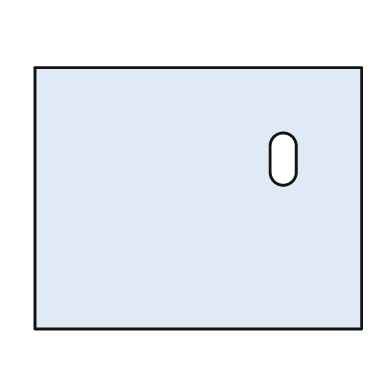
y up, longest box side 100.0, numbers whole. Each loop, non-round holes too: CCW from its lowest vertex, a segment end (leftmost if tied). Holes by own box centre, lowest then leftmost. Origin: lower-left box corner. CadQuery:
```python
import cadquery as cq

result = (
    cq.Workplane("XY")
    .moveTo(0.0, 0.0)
    .lineTo(100.0, 0.0)
    .lineTo(100.0, 80.0)
    .lineTo(0.0, 80.0)
    .close()
    .moveTo(72.0, 48.0)
    .threePointArc((76.0, 44.0), (80.0, 48.0))
    .lineTo(80.0, 56.0)
    .threePointArc((76.0, 60.0), (72.0, 56.0))
    .close()
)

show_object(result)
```